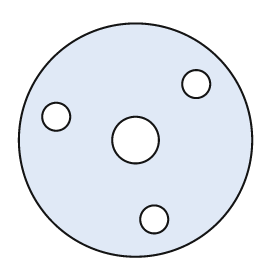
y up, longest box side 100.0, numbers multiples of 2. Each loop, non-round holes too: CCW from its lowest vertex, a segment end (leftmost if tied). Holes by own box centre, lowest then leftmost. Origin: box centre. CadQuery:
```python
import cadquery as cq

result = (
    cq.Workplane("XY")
    .moveTo(0.0, 0.0)
    .circle(50.0)
    .moveTo(8.0, -34.0)
    .circle(6.0)
    .moveTo(0.0, 0.0)
    .circle(10.0)
    .moveTo(-34.0, 10.0)
    .circle(6.0)
    .moveTo(26.0, 24.0)
    .circle(6.0)
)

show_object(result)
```